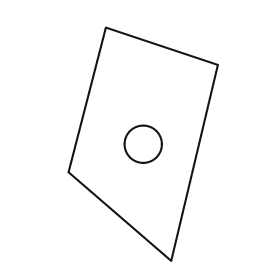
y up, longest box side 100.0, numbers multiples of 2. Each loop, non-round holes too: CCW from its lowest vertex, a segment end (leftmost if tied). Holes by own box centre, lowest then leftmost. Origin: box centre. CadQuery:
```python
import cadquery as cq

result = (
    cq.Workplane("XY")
    .moveTo(12.0, -50.0)
    .lineTo(32.0, 34.0)
    .lineTo(-16.0, 50.0)
    .lineTo(-32.0, -12.0)
    .close()
    .moveTo(0.0, 0.0)
    .circle(8.0)
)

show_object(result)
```